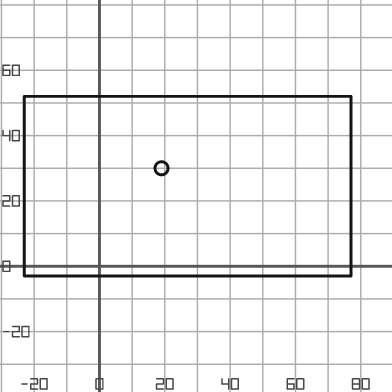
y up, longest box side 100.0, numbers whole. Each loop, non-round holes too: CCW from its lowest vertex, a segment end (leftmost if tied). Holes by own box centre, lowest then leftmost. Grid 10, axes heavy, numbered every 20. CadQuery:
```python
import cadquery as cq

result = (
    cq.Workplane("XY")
    .moveTo(-23.0, -3.0)
    .lineTo(77.0, -3.0)
    .lineTo(77.0, 52.0)
    .lineTo(-23.0, 52.0)
    .close()
    .moveTo(19.0, 30.0)
    .circle(2.0)
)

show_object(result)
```